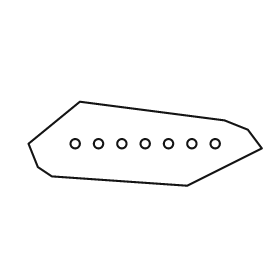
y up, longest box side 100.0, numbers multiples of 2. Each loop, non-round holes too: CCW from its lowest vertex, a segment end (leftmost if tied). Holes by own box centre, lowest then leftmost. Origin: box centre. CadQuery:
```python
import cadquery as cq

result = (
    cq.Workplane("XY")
    .moveTo(18.0, -18.0)
    .lineTo(50.0, -2.0)
    .lineTo(44.0, 6.0)
    .lineTo(34.0, 10.0)
    .lineTo(-28.0, 18.0)
    .lineTo(-50.0, 0.0)
    .lineTo(-46.0, -10.0)
    .lineTo(-40.0, -14.0)
    .close()
    .moveTo(-30.0, 0.0)
    .circle(2.0)
    .moveTo(-20.0, 0.0)
    .circle(2.0)
    .moveTo(-10.0, 0.0)
    .circle(2.0)
    .moveTo(0.0, 0.0)
    .circle(2.0)
    .moveTo(10.0, 0.0)
    .circle(2.0)
    .moveTo(20.0, 0.0)
    .circle(2.0)
    .moveTo(30.0, 0.0)
    .circle(2.0)
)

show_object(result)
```